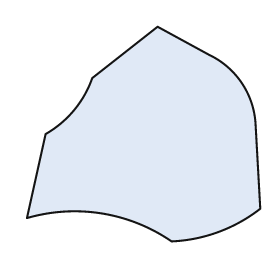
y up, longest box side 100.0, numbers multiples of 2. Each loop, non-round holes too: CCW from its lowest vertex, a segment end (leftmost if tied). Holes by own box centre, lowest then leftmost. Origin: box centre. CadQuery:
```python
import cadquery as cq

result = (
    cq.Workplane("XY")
    .moveTo(12.0, -46.0)
    .threePointArc((32.0, -42.0), (50.0, -32.0))
    .lineTo(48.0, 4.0)
    .threePointArc((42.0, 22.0), (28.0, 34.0))
    .lineTo(6.0, 46.0)
    .lineTo(-22.0, 24.0)
    .threePointArc((-30.0, 10.0), (-42.0, 0.0))
    .lineTo(-50.0, -36.0)
    .threePointArc((-18.0, -34.0), (12.0, -46.0))
    .close()
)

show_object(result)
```